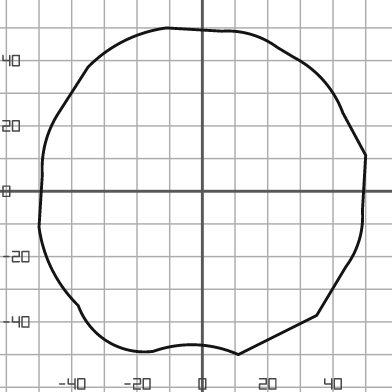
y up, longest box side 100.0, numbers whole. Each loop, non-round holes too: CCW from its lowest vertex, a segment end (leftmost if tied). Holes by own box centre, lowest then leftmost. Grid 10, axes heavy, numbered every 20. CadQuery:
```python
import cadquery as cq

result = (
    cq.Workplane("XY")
    .moveTo(11.0, -50.0)
    .lineTo(35.0, -38.0)
    .lineTo(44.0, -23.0)
    .threePointArc((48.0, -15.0), (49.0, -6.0))
    .lineTo(50.0, 11.0)
    .lineTo(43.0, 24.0)
    .threePointArc((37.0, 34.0), (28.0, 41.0))
    .lineTo(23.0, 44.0)
    .threePointArc((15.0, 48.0), (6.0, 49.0))
    .lineTo(-11.0, 50.0)
    .threePointArc((-24.0, 46.0), (-35.0, 38.0))
    .lineTo(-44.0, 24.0)
    .threePointArc((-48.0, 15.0), (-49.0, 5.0))
    .lineTo(-50.0, -11.0)
    .threePointArc((-46.0, -24.0), (-38.0, -35.0))
    .threePointArc((-29.0, -46.0), (-15.0, -49.0))
    .threePointArc((-2.0, -47.0), (11.0, -50.0))
    .close()
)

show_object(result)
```